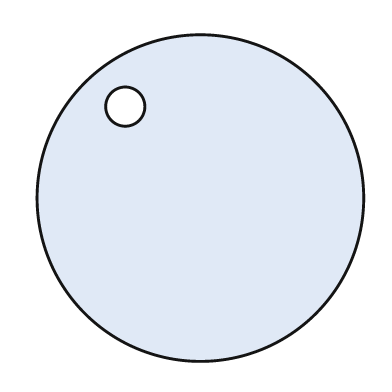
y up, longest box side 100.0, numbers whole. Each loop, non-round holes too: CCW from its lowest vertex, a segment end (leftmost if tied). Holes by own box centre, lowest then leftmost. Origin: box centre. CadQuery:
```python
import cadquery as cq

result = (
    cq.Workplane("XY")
    .moveTo(0.0, 0.0)
    .circle(50.0)
    .moveTo(-23.0, 28.0)
    .circle(6.0)
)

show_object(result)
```